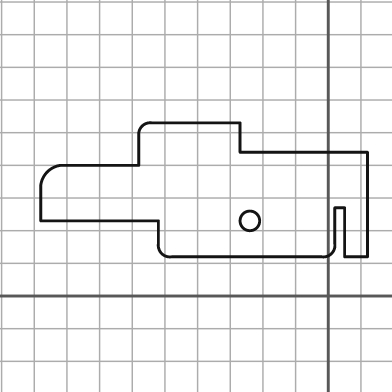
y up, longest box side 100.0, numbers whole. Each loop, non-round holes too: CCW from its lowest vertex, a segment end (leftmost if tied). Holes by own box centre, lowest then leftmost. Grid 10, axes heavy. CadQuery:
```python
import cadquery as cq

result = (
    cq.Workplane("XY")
    .moveTo(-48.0, 12.0)
    .lineTo(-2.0, 12.0)
    .threePointArc((1.0, 13.0), (2.0, 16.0))
    .lineTo(2.0, 27.0)
    .lineTo(5.0, 27.0)
    .lineTo(5.0, 12.0)
    .lineTo(12.0, 12.0)
    .lineTo(12.0, 44.0)
    .lineTo(-27.0, 44.0)
    .lineTo(-27.0, 53.0)
    .lineTo(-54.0, 53.0)
    .threePointArc((-57.0, 52.0), (-58.0, 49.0))
    .lineTo(-58.0, 40.0)
    .lineTo(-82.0, 40.0)
    .threePointArc((-86.0, 38.0), (-88.0, 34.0))
    .lineTo(-88.0, 23.0)
    .lineTo(-52.0, 23.0)
    .lineTo(-52.0, 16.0)
    .threePointArc((-51.0, 13.0), (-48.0, 12.0))
    .close()
    .moveTo(-24.0, 23.0)
    .circle(3.0)
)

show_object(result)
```